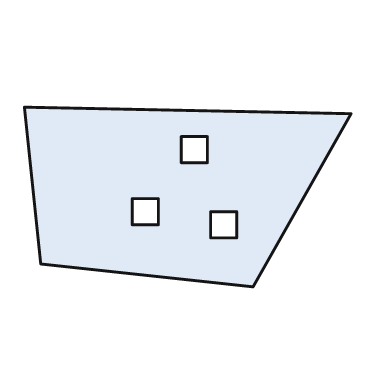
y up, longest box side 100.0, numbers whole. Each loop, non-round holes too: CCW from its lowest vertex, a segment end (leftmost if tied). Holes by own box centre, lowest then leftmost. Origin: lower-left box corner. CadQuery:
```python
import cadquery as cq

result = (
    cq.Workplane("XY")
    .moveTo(70.0, 0.0)
    .lineTo(100.0, 53.0)
    .lineTo(0.0, 55.0)
    .lineTo(5.0, 7.0)
    .close()
    .moveTo(57.0, 15.0)
    .lineTo(65.0, 15.0)
    .lineTo(65.0, 23.0)
    .lineTo(57.0, 23.0)
    .close()
    .moveTo(33.0, 19.0)
    .lineTo(41.0, 19.0)
    .lineTo(41.0, 27.0)
    .lineTo(33.0, 27.0)
    .close()
    .moveTo(48.0, 38.0)
    .lineTo(56.0, 38.0)
    .lineTo(56.0, 46.0)
    .lineTo(48.0, 46.0)
    .close()
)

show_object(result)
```